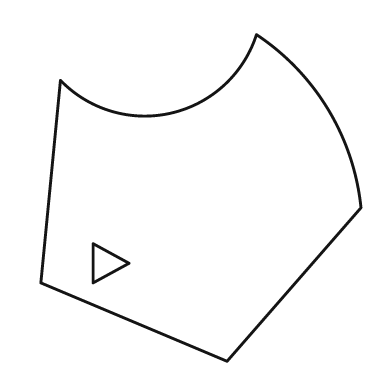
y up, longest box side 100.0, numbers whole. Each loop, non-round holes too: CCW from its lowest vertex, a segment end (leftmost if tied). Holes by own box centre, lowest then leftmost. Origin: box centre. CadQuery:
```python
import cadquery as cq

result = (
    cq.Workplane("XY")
    .moveTo(8.0, -50.0)
    .lineTo(49.0, -3.0)
    .threePointArc((39.0, 27.0), (17.0, 50.0))
    .threePointArc((-9.0, 26.0), (-43.0, 36.0))
    .lineTo(-49.0, -26.0)
    .close()
    .moveTo(-33.0, -26.0)
    .lineTo(-22.0, -20.0)
    .lineTo(-33.0, -14.0)
    .close()
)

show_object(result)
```